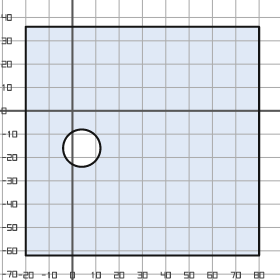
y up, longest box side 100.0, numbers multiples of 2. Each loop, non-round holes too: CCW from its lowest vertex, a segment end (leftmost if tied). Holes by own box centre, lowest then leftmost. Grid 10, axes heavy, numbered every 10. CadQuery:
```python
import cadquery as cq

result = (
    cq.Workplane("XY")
    .moveTo(-20.0, -62.0)
    .lineTo(80.0, -62.0)
    .lineTo(80.0, 36.0)
    .lineTo(-20.0, 36.0)
    .close()
    .moveTo(4.0, -16.0)
    .circle(8.0)
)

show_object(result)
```